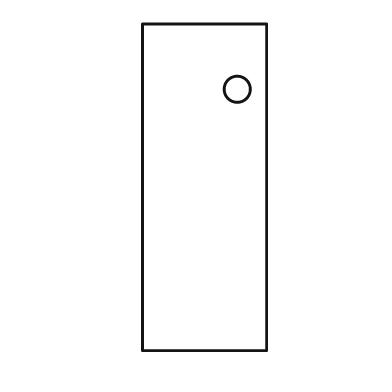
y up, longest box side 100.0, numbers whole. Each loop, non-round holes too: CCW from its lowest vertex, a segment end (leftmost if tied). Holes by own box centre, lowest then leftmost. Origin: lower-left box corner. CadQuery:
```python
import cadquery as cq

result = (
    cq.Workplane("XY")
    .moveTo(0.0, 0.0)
    .lineTo(38.0, 0.0)
    .lineTo(38.0, 100.0)
    .lineTo(0.0, 100.0)
    .close()
    .moveTo(29.0, 80.0)
    .circle(4.0)
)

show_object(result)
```